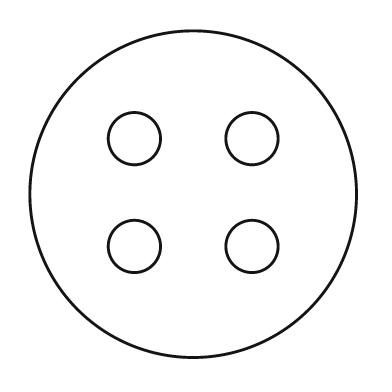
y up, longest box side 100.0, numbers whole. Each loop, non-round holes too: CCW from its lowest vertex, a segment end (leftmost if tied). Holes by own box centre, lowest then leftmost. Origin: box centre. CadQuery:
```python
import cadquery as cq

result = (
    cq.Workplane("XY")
    .moveTo(0.0, 0.0)
    .circle(50.0)
    .moveTo(-18.0, -16.0)
    .circle(8.0)
    .moveTo(18.0, -16.0)
    .circle(8.0)
    .moveTo(-18.0, 17.0)
    .circle(8.0)
    .moveTo(18.0, 17.0)
    .circle(8.0)
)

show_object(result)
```